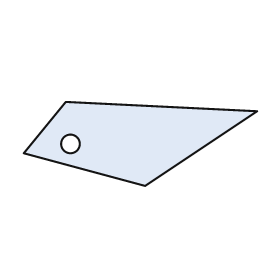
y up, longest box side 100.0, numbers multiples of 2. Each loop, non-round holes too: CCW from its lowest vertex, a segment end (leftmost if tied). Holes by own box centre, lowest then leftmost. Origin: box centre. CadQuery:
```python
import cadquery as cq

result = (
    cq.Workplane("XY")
    .moveTo(2.0, -18.0)
    .lineTo(50.0, 14.0)
    .lineTo(-32.0, 18.0)
    .lineTo(-50.0, -4.0)
    .close()
    .moveTo(-30.0, 0.0)
    .circle(4.0)
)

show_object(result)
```